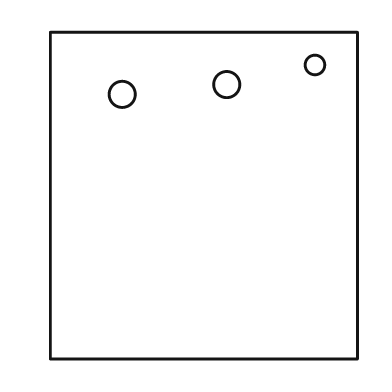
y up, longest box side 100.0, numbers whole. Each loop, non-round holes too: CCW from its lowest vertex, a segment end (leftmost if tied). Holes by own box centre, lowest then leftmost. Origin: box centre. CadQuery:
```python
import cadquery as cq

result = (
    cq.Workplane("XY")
    .moveTo(-47.0, -50.0)
    .lineTo(47.0, -50.0)
    .lineTo(47.0, 50.0)
    .lineTo(-47.0, 50.0)
    .close()
    .moveTo(-25.0, 31.0)
    .circle(4.0)
    .moveTo(7.0, 34.0)
    .circle(4.0)
    .moveTo(34.0, 40.0)
    .circle(3.0)
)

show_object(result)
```